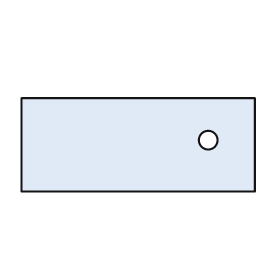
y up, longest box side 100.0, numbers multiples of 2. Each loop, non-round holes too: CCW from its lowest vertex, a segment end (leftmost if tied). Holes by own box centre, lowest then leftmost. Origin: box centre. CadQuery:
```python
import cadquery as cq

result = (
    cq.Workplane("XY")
    .moveTo(-50.0, -20.0)
    .lineTo(50.0, -20.0)
    .lineTo(50.0, 20.0)
    .lineTo(-50.0, 20.0)
    .close()
    .moveTo(30.0, 2.0)
    .circle(4.0)
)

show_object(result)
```